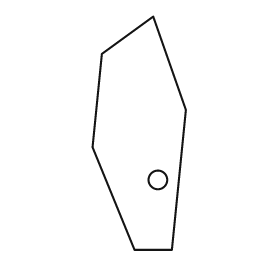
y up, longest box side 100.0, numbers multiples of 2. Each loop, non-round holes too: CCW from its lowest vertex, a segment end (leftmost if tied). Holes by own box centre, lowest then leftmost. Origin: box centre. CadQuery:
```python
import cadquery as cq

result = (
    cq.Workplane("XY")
    .moveTo(-2.0, -50.0)
    .lineTo(14.0, -50.0)
    .lineTo(20.0, 10.0)
    .lineTo(6.0, 50.0)
    .lineTo(-16.0, 34.0)
    .lineTo(-20.0, -6.0)
    .close()
    .moveTo(8.0, -20.0)
    .circle(4.0)
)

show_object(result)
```